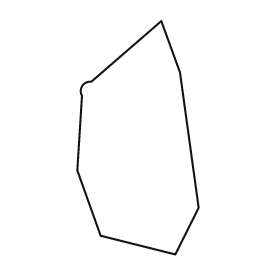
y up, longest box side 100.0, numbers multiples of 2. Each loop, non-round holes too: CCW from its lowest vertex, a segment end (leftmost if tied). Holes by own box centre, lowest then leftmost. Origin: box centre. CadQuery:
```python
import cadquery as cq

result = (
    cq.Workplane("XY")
    .moveTo(16.0, -50.0)
    .lineTo(26.0, -30.0)
    .lineTo(18.0, 28.0)
    .lineTo(10.0, 50.0)
    .lineTo(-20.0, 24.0)
    .threePointArc((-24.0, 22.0), (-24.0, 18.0))
    .lineTo(-26.0, -14.0)
    .lineTo(-16.0, -42.0)
    .close()
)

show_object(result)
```